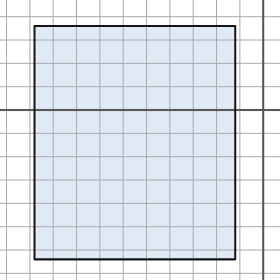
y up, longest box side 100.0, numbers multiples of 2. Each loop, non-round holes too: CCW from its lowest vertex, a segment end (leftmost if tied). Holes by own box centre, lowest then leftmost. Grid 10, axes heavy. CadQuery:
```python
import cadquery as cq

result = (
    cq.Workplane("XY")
    .moveTo(-98.0, -64.0)
    .lineTo(-12.0, -64.0)
    .lineTo(-12.0, 36.0)
    .lineTo(-98.0, 36.0)
    .close()
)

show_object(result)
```